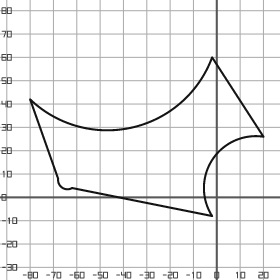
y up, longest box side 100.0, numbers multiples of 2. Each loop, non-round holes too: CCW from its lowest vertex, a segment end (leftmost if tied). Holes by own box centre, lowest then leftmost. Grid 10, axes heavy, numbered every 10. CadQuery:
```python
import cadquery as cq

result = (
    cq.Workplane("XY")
    .moveTo(-2.0, -8.0)
    .threePointArc((-2.0, 16.0), (20.0, 26.0))
    .lineTo(-2.0, 60.0)
    .threePointArc((-36.0, 30.0), (-80.0, 42.0))
    .lineTo(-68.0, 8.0)
    .threePointArc((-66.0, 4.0), (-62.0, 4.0))
    .close()
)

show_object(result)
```